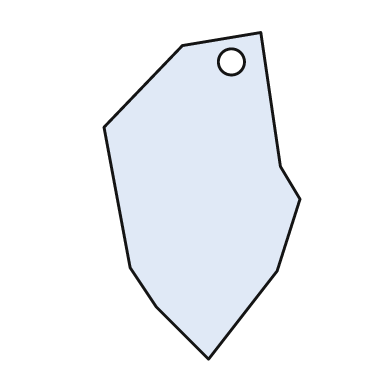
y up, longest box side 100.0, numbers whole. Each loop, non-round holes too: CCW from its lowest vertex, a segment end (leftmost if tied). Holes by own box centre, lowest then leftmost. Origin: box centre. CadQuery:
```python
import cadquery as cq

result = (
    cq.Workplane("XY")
    .moveTo(2.0, -50.0)
    .lineTo(23.0, -23.0)
    .lineTo(30.0, -1.0)
    .lineTo(24.0, 9.0)
    .lineTo(18.0, 50.0)
    .lineTo(-6.0, 46.0)
    .lineTo(-30.0, 21.0)
    .lineTo(-22.0, -22.0)
    .lineTo(-14.0, -34.0)
    .close()
    .moveTo(9.0, 41.0)
    .circle(4.0)
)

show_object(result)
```